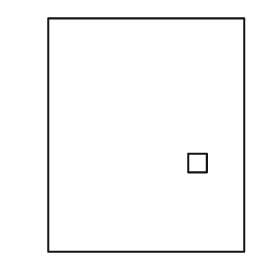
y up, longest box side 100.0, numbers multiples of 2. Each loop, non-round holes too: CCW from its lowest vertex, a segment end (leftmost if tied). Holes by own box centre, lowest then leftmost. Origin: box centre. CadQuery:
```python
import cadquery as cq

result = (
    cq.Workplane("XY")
    .moveTo(-42.0, -50.0)
    .lineTo(42.0, -50.0)
    .lineTo(42.0, 50.0)
    .lineTo(-42.0, 50.0)
    .close()
    .moveTo(18.0, -16.0)
    .lineTo(26.0, -16.0)
    .lineTo(26.0, -8.0)
    .lineTo(18.0, -8.0)
    .close()
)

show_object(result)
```